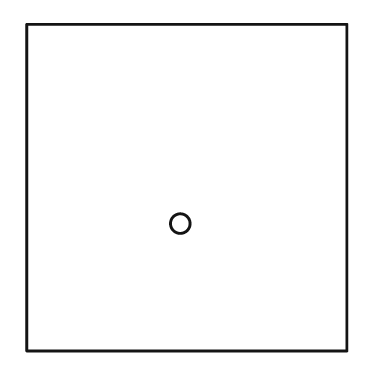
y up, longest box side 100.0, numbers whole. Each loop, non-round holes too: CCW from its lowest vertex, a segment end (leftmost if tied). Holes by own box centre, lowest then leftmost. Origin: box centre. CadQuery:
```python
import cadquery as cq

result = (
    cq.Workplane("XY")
    .moveTo(-49.0, -50.0)
    .lineTo(49.0, -50.0)
    .lineTo(49.0, 50.0)
    .lineTo(-49.0, 50.0)
    .close()
    .moveTo(-2.0, -11.0)
    .circle(3.0)
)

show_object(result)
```